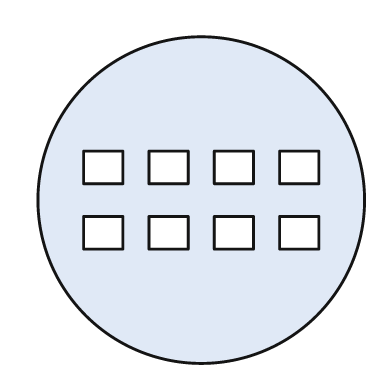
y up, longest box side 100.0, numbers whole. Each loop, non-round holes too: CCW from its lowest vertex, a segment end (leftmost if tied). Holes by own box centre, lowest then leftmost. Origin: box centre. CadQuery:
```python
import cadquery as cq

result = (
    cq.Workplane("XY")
    .moveTo(0.0, 0.0)
    .circle(50.0)
    .moveTo(-36.0, -15.0)
    .lineTo(-24.0, -15.0)
    .lineTo(-24.0, -5.0)
    .lineTo(-36.0, -5.0)
    .close()
    .moveTo(-16.0, -15.0)
    .lineTo(-4.0, -15.0)
    .lineTo(-4.0, -5.0)
    .lineTo(-16.0, -5.0)
    .close()
    .moveTo(4.0, -15.0)
    .lineTo(16.0, -15.0)
    .lineTo(16.0, -5.0)
    .lineTo(4.0, -5.0)
    .close()
    .moveTo(24.0, -15.0)
    .lineTo(36.0, -15.0)
    .lineTo(36.0, -5.0)
    .lineTo(24.0, -5.0)
    .close()
    .moveTo(-36.0, 5.0)
    .lineTo(-24.0, 5.0)
    .lineTo(-24.0, 15.0)
    .lineTo(-36.0, 15.0)
    .close()
    .moveTo(-16.0, 5.0)
    .lineTo(-4.0, 5.0)
    .lineTo(-4.0, 15.0)
    .lineTo(-16.0, 15.0)
    .close()
    .moveTo(4.0, 5.0)
    .lineTo(16.0, 5.0)
    .lineTo(16.0, 15.0)
    .lineTo(4.0, 15.0)
    .close()
    .moveTo(24.0, 5.0)
    .lineTo(36.0, 5.0)
    .lineTo(36.0, 15.0)
    .lineTo(24.0, 15.0)
    .close()
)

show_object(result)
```